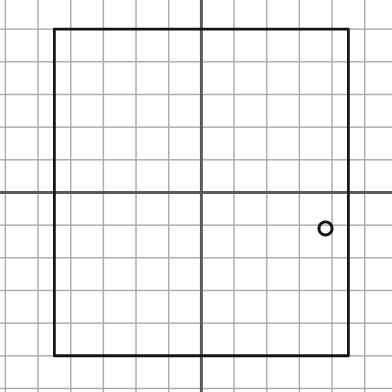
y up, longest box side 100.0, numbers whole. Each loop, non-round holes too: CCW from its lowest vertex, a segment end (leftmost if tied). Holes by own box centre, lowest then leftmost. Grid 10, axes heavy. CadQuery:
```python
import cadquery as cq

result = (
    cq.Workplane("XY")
    .moveTo(-45.0, -50.0)
    .lineTo(45.0, -50.0)
    .lineTo(45.0, 50.0)
    .lineTo(-45.0, 50.0)
    .close()
    .moveTo(38.0, -11.0)
    .circle(2.0)
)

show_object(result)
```